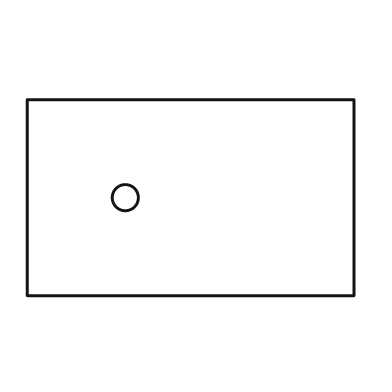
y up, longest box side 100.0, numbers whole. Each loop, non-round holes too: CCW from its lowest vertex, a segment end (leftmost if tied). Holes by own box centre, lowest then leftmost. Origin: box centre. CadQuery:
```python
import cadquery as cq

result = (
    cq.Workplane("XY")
    .moveTo(-50.0, -30.0)
    .lineTo(50.0, -30.0)
    .lineTo(50.0, 30.0)
    .lineTo(-50.0, 30.0)
    .close()
    .moveTo(-20.0, 0.0)
    .circle(4.0)
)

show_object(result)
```